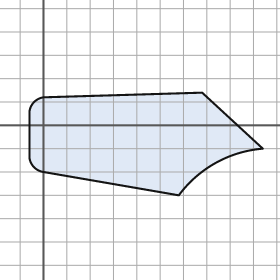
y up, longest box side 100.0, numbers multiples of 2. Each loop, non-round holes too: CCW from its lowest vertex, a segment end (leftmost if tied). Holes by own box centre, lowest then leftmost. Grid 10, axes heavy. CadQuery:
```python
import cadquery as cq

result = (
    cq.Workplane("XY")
    .moveTo(58.0, -30.0)
    .threePointArc((74.0, -16.0), (94.0, -10.0))
    .lineTo(68.0, 14.0)
    .lineTo(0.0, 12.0)
    .threePointArc((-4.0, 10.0), (-6.0, 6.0))
    .lineTo(-6.0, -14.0)
    .threePointArc((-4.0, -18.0), (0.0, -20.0))
    .close()
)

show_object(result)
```